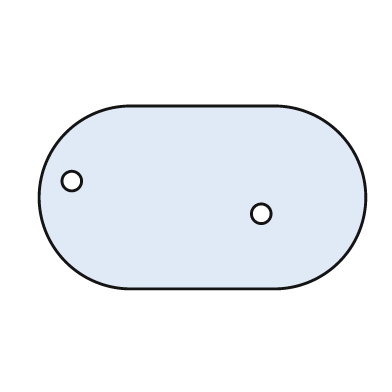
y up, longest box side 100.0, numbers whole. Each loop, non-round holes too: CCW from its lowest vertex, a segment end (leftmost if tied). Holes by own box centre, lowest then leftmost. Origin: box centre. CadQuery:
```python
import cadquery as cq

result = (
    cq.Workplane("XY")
    .moveTo(-22.0, -28.0)
    .lineTo(22.0, -28.0)
    .threePointArc((50.0, 0.0), (22.0, 28.0))
    .lineTo(-22.0, 28.0)
    .threePointArc((-50.0, 0.0), (-22.0, -28.0))
    .close()
    .moveTo(18.0, -5.0)
    .circle(3.0)
    .moveTo(-40.0, 5.0)
    .circle(3.0)
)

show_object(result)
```